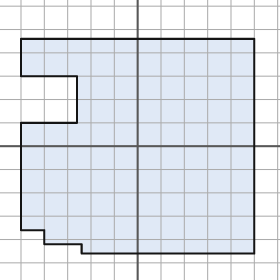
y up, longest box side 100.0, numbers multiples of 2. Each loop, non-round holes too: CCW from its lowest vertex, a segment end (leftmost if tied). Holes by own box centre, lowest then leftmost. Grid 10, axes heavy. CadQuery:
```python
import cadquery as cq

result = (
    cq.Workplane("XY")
    .moveTo(-24.0, -46.0)
    .lineTo(50.0, -46.0)
    .lineTo(50.0, 46.0)
    .lineTo(-50.0, 46.0)
    .lineTo(-50.0, 30.0)
    .lineTo(-26.0, 30.0)
    .lineTo(-26.0, 10.0)
    .lineTo(-50.0, 10.0)
    .lineTo(-50.0, -36.0)
    .lineTo(-40.0, -36.0)
    .lineTo(-40.0, -42.0)
    .lineTo(-24.0, -42.0)
    .close()
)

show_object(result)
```